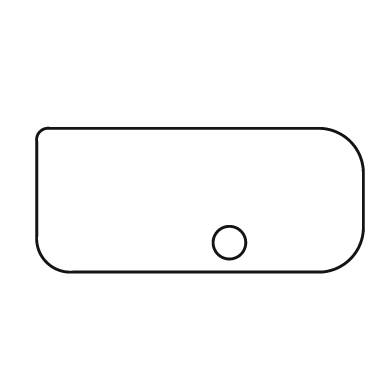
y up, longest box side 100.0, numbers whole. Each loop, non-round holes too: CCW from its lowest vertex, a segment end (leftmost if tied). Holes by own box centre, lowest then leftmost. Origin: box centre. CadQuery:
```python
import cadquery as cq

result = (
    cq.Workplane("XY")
    .moveTo(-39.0, -22.0)
    .lineTo(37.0, -22.0)
    .threePointArc((46.0, -18.0), (50.0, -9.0))
    .lineTo(50.0, 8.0)
    .threePointArc((46.0, 18.0), (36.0, 22.0))
    .lineTo(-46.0, 22.0)
    .threePointArc((-49.0, 21.0), (-50.0, 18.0))
    .lineTo(-50.0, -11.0)
    .threePointArc((-47.0, -19.0), (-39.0, -22.0))
    .close()
    .moveTo(9.0, -13.0)
    .circle(5.0)
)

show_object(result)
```